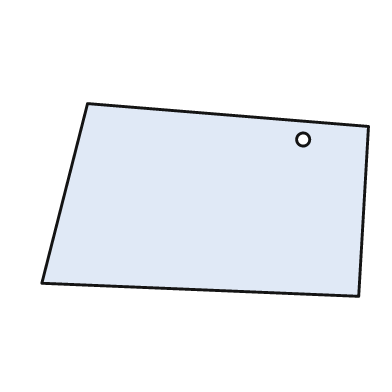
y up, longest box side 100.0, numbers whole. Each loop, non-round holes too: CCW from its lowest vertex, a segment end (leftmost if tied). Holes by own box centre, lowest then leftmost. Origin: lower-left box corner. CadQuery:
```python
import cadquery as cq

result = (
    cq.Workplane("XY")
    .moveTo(97.0, 0.0)
    .lineTo(100.0, 52.0)
    .lineTo(14.0, 59.0)
    .lineTo(0.0, 4.0)
    .close()
    .moveTo(80.0, 48.0)
    .circle(2.0)
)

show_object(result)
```